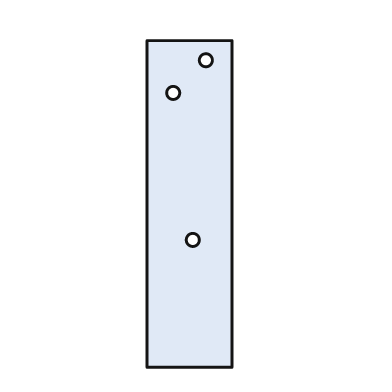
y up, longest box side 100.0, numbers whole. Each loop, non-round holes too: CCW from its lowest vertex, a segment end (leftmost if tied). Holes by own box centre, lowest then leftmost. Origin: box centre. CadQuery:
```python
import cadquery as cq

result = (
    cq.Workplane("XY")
    .moveTo(-13.0, -50.0)
    .lineTo(13.0, -50.0)
    .lineTo(13.0, 50.0)
    .lineTo(-13.0, 50.0)
    .close()
    .moveTo(1.0, -11.0)
    .circle(2.0)
    .moveTo(-5.0, 34.0)
    .circle(2.0)
    .moveTo(5.0, 44.0)
    .circle(2.0)
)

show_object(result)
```